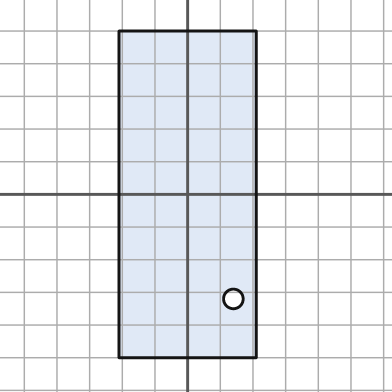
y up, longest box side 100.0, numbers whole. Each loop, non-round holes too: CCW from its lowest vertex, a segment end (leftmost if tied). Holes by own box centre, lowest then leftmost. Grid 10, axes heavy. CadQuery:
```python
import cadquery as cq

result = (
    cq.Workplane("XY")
    .moveTo(-21.0, -50.0)
    .lineTo(21.0, -50.0)
    .lineTo(21.0, 50.0)
    .lineTo(-21.0, 50.0)
    .close()
    .moveTo(14.0, -32.0)
    .circle(3.0)
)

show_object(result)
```